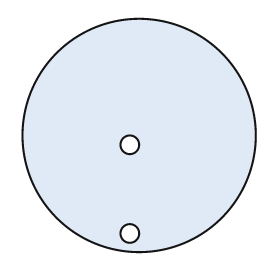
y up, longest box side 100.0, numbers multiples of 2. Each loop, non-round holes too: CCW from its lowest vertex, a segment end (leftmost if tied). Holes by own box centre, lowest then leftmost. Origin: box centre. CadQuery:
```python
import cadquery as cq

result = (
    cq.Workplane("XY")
    .moveTo(0.0, 0.0)
    .circle(50.0)
    .moveTo(-4.0, -42.0)
    .circle(4.0)
    .moveTo(-4.0, -4.0)
    .circle(4.0)
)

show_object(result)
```